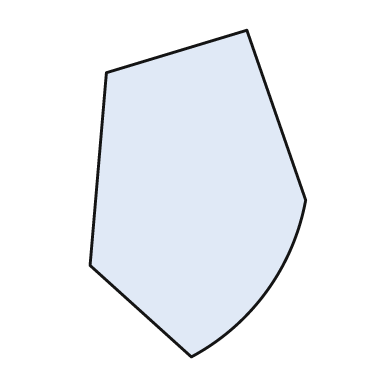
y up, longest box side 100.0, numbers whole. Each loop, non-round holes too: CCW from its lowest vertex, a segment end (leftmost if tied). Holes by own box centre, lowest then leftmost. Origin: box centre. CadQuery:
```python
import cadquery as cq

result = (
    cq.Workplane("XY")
    .moveTo(-2.0, -50.0)
    .threePointArc((21.0, -30.0), (33.0, -2.0))
    .lineTo(15.0, 50.0)
    .lineTo(-28.0, 37.0)
    .lineTo(-33.0, -22.0)
    .close()
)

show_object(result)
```